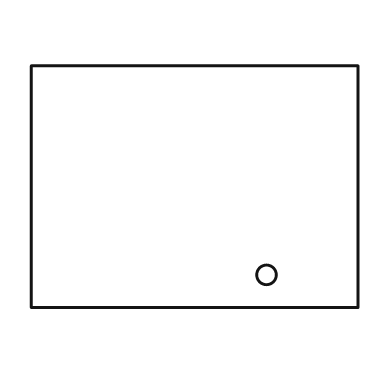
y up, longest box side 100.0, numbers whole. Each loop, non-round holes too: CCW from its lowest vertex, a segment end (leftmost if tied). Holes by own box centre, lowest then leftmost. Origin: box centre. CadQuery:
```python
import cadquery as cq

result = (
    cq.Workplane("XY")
    .moveTo(-50.0, -37.0)
    .lineTo(50.0, -37.0)
    .lineTo(50.0, 37.0)
    .lineTo(-50.0, 37.0)
    .close()
    .moveTo(22.0, -27.0)
    .circle(3.0)
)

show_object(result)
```